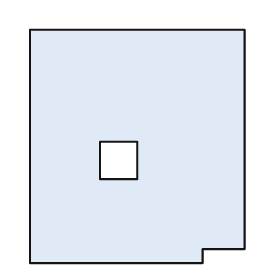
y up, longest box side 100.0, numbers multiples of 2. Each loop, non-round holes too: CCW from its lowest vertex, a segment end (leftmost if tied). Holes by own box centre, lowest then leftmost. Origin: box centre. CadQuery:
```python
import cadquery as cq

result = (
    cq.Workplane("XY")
    .moveTo(-46.0, -50.0)
    .lineTo(28.0, -50.0)
    .lineTo(28.0, -44.0)
    .lineTo(46.0, -44.0)
    .lineTo(46.0, 50.0)
    .lineTo(-46.0, 50.0)
    .close()
    .moveTo(-16.0, -14.0)
    .lineTo(0.0, -14.0)
    .lineTo(0.0, 2.0)
    .lineTo(-16.0, 2.0)
    .close()
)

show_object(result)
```